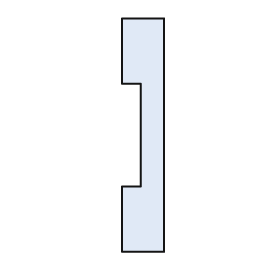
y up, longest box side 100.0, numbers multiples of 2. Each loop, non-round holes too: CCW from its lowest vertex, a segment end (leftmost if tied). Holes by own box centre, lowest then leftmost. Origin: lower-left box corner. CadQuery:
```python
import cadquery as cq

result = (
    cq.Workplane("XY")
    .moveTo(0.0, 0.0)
    .lineTo(18.0, 0.0)
    .lineTo(18.0, 100.0)
    .lineTo(0.0, 100.0)
    .lineTo(0.0, 72.0)
    .lineTo(8.0, 72.0)
    .lineTo(8.0, 28.0)
    .lineTo(0.0, 28.0)
    .close()
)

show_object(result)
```